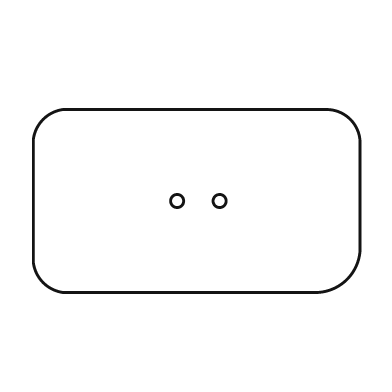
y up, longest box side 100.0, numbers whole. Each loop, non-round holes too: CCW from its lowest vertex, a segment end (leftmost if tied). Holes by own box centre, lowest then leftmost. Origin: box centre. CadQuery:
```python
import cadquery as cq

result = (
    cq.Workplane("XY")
    .moveTo(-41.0, -28.0)
    .lineTo(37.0, -28.0)
    .threePointArc((46.0, -24.0), (50.0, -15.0))
    .lineTo(50.0, 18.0)
    .threePointArc((47.0, 25.0), (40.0, 28.0))
    .lineTo(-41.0, 28.0)
    .threePointArc((-47.0, 25.0), (-50.0, 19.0))
    .lineTo(-50.0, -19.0)
    .threePointArc((-47.0, -25.0), (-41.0, -28.0))
    .close()
    .moveTo(-6.0, 0.0)
    .circle(2.0)
    .moveTo(7.0, 0.0)
    .circle(2.0)
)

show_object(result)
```